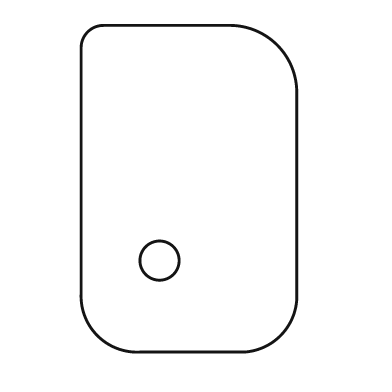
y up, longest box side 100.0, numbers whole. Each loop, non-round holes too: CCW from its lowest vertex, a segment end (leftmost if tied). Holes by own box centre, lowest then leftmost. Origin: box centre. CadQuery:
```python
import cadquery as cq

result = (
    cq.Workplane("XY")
    .moveTo(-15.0, -50.0)
    .lineTo(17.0, -50.0)
    .threePointArc((28.0, -45.0), (33.0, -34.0))
    .lineTo(33.0, 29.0)
    .threePointArc((27.0, 44.0), (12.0, 50.0))
    .lineTo(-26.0, 50.0)
    .threePointArc((-31.0, 48.0), (-33.0, 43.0))
    .lineTo(-33.0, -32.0)
    .threePointArc((-28.0, -45.0), (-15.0, -50.0))
    .close()
    .moveTo(-9.0, -22.0)
    .circle(6.0)
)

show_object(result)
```